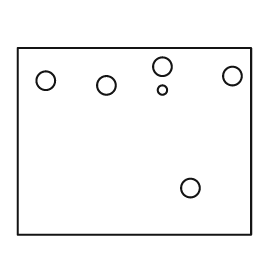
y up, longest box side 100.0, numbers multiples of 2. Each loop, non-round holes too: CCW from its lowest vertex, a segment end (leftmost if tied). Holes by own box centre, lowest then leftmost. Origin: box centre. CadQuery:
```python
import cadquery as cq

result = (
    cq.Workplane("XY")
    .moveTo(-50.0, -40.0)
    .lineTo(50.0, -40.0)
    .lineTo(50.0, 40.0)
    .lineTo(-50.0, 40.0)
    .close()
    .moveTo(24.0, -20.0)
    .circle(4.0)
    .moveTo(12.0, 22.0)
    .circle(2.0)
    .moveTo(-12.0, 24.0)
    .circle(4.0)
    .moveTo(-38.0, 26.0)
    .circle(4.0)
    .moveTo(42.0, 28.0)
    .circle(4.0)
    .moveTo(12.0, 32.0)
    .circle(4.0)
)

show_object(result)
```